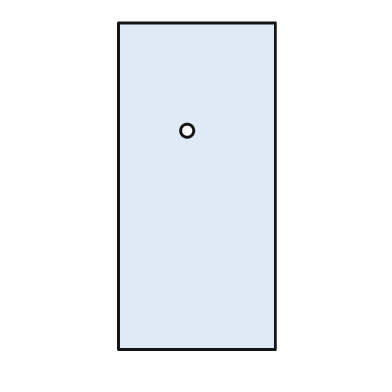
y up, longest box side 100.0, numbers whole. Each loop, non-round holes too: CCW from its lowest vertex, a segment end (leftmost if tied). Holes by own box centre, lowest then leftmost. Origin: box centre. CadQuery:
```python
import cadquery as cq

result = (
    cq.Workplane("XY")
    .moveTo(-24.0, -50.0)
    .lineTo(24.0, -50.0)
    .lineTo(24.0, 50.0)
    .lineTo(-24.0, 50.0)
    .close()
    .moveTo(-3.0, 17.0)
    .circle(2.0)
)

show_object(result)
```